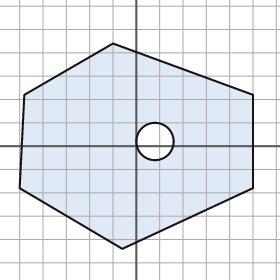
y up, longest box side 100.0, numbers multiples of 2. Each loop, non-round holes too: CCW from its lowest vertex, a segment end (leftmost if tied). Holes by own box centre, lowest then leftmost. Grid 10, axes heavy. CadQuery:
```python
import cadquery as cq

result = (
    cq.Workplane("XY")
    .moveTo(-6.0, -44.0)
    .lineTo(50.0, -18.0)
    .lineTo(50.0, 22.0)
    .lineTo(-10.0, 44.0)
    .lineTo(-48.0, 22.0)
    .lineTo(-50.0, -18.0)
    .close()
    .moveTo(8.0, 2.0)
    .circle(8.0)
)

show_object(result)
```